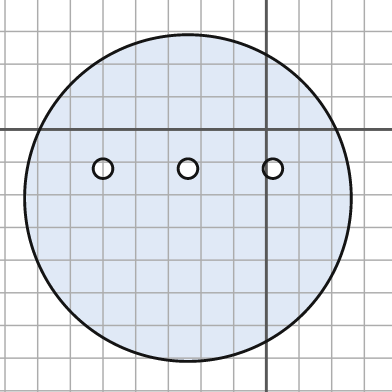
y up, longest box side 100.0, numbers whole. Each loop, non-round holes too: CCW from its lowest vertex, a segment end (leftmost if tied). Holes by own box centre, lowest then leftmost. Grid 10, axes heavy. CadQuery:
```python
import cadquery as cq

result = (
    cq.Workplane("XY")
    .moveTo(-24.0, -21.0)
    .circle(50.0)
    .moveTo(-50.0, -12.0)
    .circle(3.0)
    .moveTo(-24.0, -12.0)
    .circle(3.0)
    .moveTo(2.0, -12.0)
    .circle(3.0)
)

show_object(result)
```